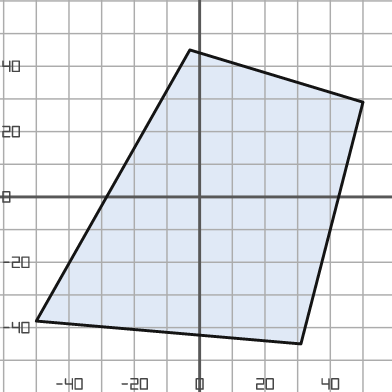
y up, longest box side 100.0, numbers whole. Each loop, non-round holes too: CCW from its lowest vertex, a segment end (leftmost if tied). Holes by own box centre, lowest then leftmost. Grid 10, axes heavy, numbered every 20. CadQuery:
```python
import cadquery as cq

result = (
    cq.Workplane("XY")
    .moveTo(31.0, -45.0)
    .lineTo(50.0, 29.0)
    .lineTo(-3.0, 45.0)
    .lineTo(-50.0, -38.0)
    .close()
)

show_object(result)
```